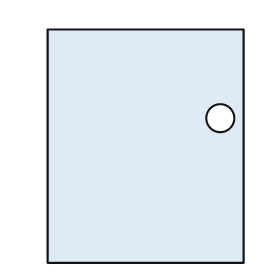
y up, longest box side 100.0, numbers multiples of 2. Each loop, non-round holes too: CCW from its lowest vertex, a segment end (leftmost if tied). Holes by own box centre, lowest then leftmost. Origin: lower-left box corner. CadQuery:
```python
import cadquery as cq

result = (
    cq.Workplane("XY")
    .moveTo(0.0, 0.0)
    .lineTo(84.0, 0.0)
    .lineTo(84.0, 100.0)
    .lineTo(0.0, 100.0)
    .close()
    .moveTo(74.0, 62.0)
    .circle(6.0)
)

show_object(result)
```